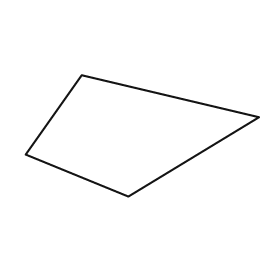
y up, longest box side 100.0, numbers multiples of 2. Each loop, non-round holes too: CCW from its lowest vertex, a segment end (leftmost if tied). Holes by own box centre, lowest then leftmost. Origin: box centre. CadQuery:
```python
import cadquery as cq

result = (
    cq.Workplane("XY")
    .moveTo(-6.0, -26.0)
    .lineTo(50.0, 8.0)
    .lineTo(-26.0, 26.0)
    .lineTo(-50.0, -8.0)
    .close()
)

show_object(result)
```